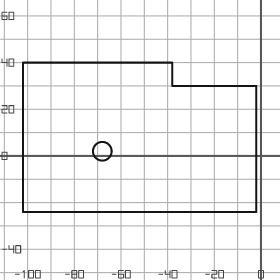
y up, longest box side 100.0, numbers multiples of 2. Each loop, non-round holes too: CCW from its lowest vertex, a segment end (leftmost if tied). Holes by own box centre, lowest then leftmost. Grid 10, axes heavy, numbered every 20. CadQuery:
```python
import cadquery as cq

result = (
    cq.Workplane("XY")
    .moveTo(-102.0, -24.0)
    .lineTo(-2.0, -24.0)
    .lineTo(-2.0, 30.0)
    .lineTo(-38.0, 30.0)
    .lineTo(-38.0, 40.0)
    .lineTo(-102.0, 40.0)
    .close()
    .moveTo(-68.0, 2.0)
    .circle(4.0)
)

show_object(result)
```